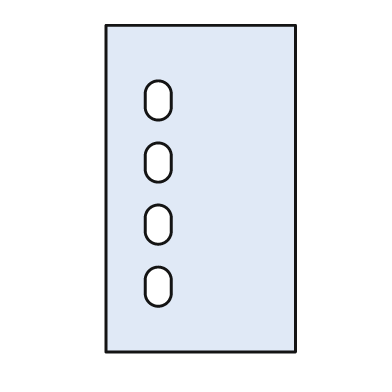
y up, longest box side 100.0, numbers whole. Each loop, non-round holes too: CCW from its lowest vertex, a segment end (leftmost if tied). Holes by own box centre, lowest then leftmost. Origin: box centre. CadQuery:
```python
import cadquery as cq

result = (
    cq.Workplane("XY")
    .moveTo(-29.0, -50.0)
    .lineTo(29.0, -50.0)
    .lineTo(29.0, 50.0)
    .lineTo(-29.0, 50.0)
    .close()
    .moveTo(-17.0, -32.0)
    .threePointArc((-13.0, -36.0), (-9.0, -32.0))
    .lineTo(-9.0, -28.0)
    .threePointArc((-13.0, -24.0), (-17.0, -28.0))
    .close()
    .moveTo(-17.0, -13.0)
    .threePointArc((-13.0, -17.0), (-9.0, -13.0))
    .lineTo(-9.0, -9.0)
    .threePointArc((-13.0, -5.0), (-17.0, -9.0))
    .close()
    .moveTo(-17.0, 6.0)
    .threePointArc((-13.0, 2.0), (-9.0, 6.0))
    .lineTo(-9.0, 10.0)
    .threePointArc((-13.0, 14.0), (-17.0, 10.0))
    .close()
    .moveTo(-17.0, 25.0)
    .threePointArc((-13.0, 21.0), (-9.0, 25.0))
    .lineTo(-9.0, 29.0)
    .threePointArc((-13.0, 33.0), (-17.0, 29.0))
    .close()
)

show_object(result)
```